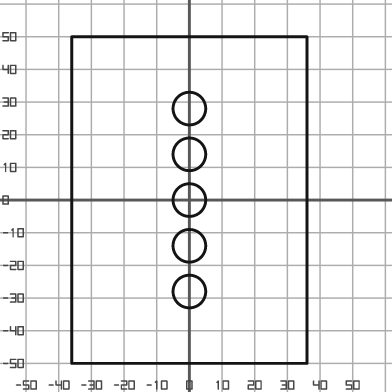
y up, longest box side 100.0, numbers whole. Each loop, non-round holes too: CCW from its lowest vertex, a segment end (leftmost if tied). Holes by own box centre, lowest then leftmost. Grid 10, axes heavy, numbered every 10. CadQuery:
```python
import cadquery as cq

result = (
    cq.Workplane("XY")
    .moveTo(-36.0, -50.0)
    .lineTo(36.0, -50.0)
    .lineTo(36.0, 50.0)
    .lineTo(-36.0, 50.0)
    .close()
    .moveTo(0.0, -28.0)
    .circle(5.0)
    .moveTo(0.0, -14.0)
    .circle(5.0)
    .moveTo(0.0, 0.0)
    .circle(5.0)
    .moveTo(0.0, 14.0)
    .circle(5.0)
    .moveTo(0.0, 28.0)
    .circle(5.0)
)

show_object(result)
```